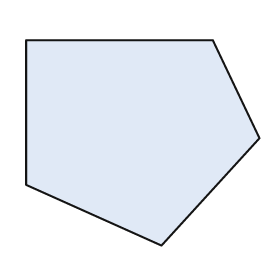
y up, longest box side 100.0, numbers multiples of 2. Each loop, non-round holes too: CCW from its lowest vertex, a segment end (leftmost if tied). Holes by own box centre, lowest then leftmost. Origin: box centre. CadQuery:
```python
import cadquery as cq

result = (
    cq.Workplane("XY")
    .moveTo(8.0, -44.0)
    .lineTo(50.0, 2.0)
    .lineTo(30.0, 44.0)
    .lineTo(-50.0, 44.0)
    .lineTo(-50.0, -18.0)
    .close()
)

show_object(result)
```